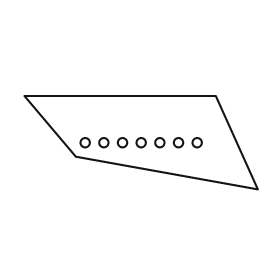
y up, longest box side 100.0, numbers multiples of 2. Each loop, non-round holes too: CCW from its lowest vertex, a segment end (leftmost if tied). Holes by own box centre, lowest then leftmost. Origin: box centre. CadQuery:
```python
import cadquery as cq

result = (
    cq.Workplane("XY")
    .moveTo(50.0, -20.0)
    .lineTo(32.0, 20.0)
    .lineTo(-50.0, 20.0)
    .lineTo(-28.0, -6.0)
    .close()
    .moveTo(-24.0, 0.0)
    .circle(2.0)
    .moveTo(-16.0, 0.0)
    .circle(2.0)
    .moveTo(-8.0, 0.0)
    .circle(2.0)
    .moveTo(0.0, 0.0)
    .circle(2.0)
    .moveTo(8.0, 0.0)
    .circle(2.0)
    .moveTo(16.0, 0.0)
    .circle(2.0)
    .moveTo(24.0, 0.0)
    .circle(2.0)
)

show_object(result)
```